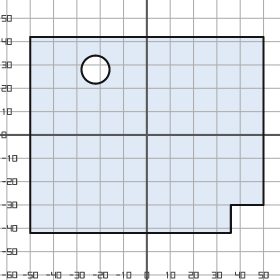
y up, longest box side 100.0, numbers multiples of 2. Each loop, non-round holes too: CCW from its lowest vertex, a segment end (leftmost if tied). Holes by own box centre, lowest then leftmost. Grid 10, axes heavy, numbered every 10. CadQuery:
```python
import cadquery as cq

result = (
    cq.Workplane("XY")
    .moveTo(-50.0, -42.0)
    .lineTo(36.0, -42.0)
    .lineTo(36.0, -30.0)
    .lineTo(50.0, -30.0)
    .lineTo(50.0, 42.0)
    .lineTo(-50.0, 42.0)
    .close()
    .moveTo(-22.0, 28.0)
    .circle(6.0)
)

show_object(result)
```